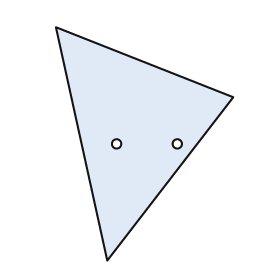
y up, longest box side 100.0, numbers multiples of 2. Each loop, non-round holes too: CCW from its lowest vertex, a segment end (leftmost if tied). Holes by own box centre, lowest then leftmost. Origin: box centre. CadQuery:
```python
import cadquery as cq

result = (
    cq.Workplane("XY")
    .moveTo(-16.0, -50.0)
    .lineTo(38.0, 20.0)
    .lineTo(-38.0, 50.0)
    .close()
    .moveTo(-12.0, 0.0)
    .circle(2.0)
    .moveTo(14.0, 0.0)
    .circle(2.0)
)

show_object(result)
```